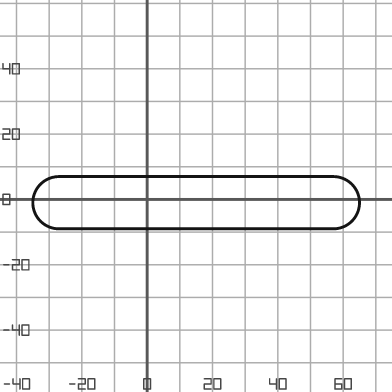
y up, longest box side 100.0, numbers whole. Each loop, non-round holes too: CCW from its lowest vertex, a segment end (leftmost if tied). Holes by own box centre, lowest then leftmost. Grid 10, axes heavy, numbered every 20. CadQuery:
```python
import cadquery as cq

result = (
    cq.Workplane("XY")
    .moveTo(-27.0, -9.0)
    .lineTo(57.0, -9.0)
    .threePointArc((65.0, -1.0), (57.0, 7.0))
    .lineTo(-27.0, 7.0)
    .threePointArc((-35.0, -1.0), (-27.0, -9.0))
    .close()
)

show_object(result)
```